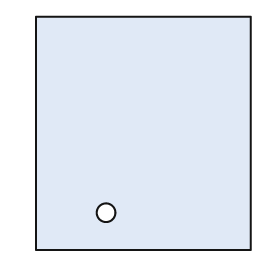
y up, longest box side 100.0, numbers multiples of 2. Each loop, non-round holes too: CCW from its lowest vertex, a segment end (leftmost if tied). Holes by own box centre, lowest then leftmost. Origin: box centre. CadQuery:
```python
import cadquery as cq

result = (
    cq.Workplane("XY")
    .moveTo(-46.0, -50.0)
    .lineTo(46.0, -50.0)
    .lineTo(46.0, 50.0)
    .lineTo(-46.0, 50.0)
    .close()
    .moveTo(-16.0, -34.0)
    .circle(4.0)
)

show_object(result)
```